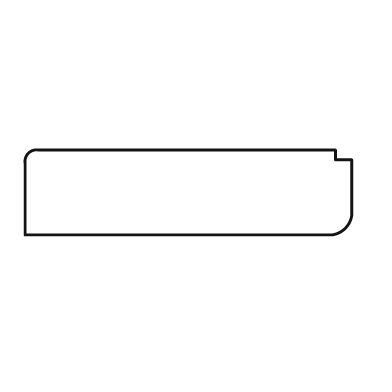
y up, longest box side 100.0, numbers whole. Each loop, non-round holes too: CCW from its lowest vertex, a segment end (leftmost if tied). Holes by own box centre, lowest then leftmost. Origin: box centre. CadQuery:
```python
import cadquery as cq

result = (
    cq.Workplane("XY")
    .moveTo(-50.0, -13.0)
    .lineTo(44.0, -13.0)
    .threePointArc((48.0, -11.0), (50.0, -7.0))
    .lineTo(50.0, 10.0)
    .lineTo(45.0, 10.0)
    .lineTo(45.0, 13.0)
    .lineTo(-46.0, 13.0)
    .threePointArc((-49.0, 12.0), (-50.0, 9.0))
    .close()
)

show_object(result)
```